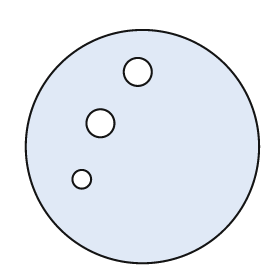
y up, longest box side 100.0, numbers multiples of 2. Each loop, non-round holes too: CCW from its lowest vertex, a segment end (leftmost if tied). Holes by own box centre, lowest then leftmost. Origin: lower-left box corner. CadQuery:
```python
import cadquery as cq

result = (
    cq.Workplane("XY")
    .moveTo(50.0, 50.0)
    .circle(50.0)
    .moveTo(24.0, 36.0)
    .circle(4.0)
    .moveTo(32.0, 60.0)
    .circle(6.0)
    .moveTo(48.0, 82.0)
    .circle(6.0)
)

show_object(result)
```